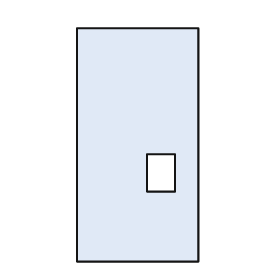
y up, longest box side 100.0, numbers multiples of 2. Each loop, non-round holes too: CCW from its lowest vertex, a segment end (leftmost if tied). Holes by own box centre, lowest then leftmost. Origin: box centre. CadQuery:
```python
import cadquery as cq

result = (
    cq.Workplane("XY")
    .moveTo(-26.0, -50.0)
    .lineTo(26.0, -50.0)
    .lineTo(26.0, 50.0)
    .lineTo(-26.0, 50.0)
    .close()
    .moveTo(4.0, -20.0)
    .lineTo(16.0, -20.0)
    .lineTo(16.0, -4.0)
    .lineTo(4.0, -4.0)
    .close()
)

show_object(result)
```